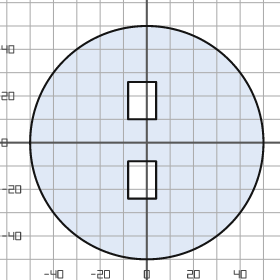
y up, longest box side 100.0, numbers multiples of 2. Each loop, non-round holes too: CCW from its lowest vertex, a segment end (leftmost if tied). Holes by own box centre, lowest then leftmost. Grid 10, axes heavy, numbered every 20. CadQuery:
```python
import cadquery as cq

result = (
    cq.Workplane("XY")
    .moveTo(0.0, 0.0)
    .circle(50.0)
    .moveTo(-8.0, -24.0)
    .lineTo(4.0, -24.0)
    .lineTo(4.0, -8.0)
    .lineTo(-8.0, -8.0)
    .close()
    .moveTo(-8.0, 10.0)
    .lineTo(4.0, 10.0)
    .lineTo(4.0, 26.0)
    .lineTo(-8.0, 26.0)
    .close()
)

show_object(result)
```